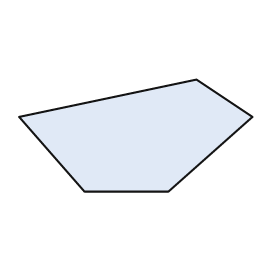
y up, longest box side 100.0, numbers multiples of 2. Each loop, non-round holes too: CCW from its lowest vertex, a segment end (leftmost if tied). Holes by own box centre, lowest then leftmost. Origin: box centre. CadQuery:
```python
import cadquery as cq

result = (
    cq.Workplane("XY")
    .moveTo(-22.0, -24.0)
    .lineTo(14.0, -24.0)
    .lineTo(50.0, 8.0)
    .lineTo(26.0, 24.0)
    .lineTo(-50.0, 8.0)
    .close()
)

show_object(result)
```